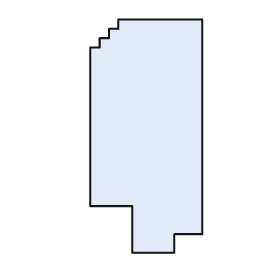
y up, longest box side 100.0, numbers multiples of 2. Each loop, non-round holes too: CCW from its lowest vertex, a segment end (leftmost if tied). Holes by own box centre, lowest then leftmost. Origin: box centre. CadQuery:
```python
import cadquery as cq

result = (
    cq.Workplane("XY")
    .moveTo(-6.0, -50.0)
    .lineTo(12.0, -50.0)
    .lineTo(12.0, -42.0)
    .lineTo(24.0, -42.0)
    .lineTo(24.0, 50.0)
    .lineTo(-12.0, 50.0)
    .lineTo(-12.0, 46.0)
    .lineTo(-16.0, 46.0)
    .lineTo(-16.0, 42.0)
    .lineTo(-20.0, 42.0)
    .lineTo(-20.0, 38.0)
    .lineTo(-24.0, 38.0)
    .lineTo(-24.0, -30.0)
    .lineTo(-6.0, -30.0)
    .close()
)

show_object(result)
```